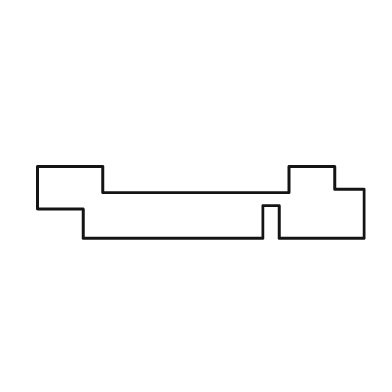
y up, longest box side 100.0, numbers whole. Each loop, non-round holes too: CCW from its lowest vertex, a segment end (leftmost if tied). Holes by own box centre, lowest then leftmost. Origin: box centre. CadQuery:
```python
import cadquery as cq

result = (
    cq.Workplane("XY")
    .moveTo(-36.0, -11.0)
    .lineTo(19.0, -11.0)
    .lineTo(19.0, -1.0)
    .lineTo(24.0, -1.0)
    .lineTo(24.0, -11.0)
    .lineTo(50.0, -11.0)
    .lineTo(50.0, 4.0)
    .lineTo(41.0, 4.0)
    .lineTo(41.0, 11.0)
    .lineTo(27.0, 11.0)
    .lineTo(27.0, 3.0)
    .lineTo(-30.0, 3.0)
    .lineTo(-30.0, 11.0)
    .lineTo(-50.0, 11.0)
    .lineTo(-50.0, -2.0)
    .lineTo(-36.0, -2.0)
    .close()
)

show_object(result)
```